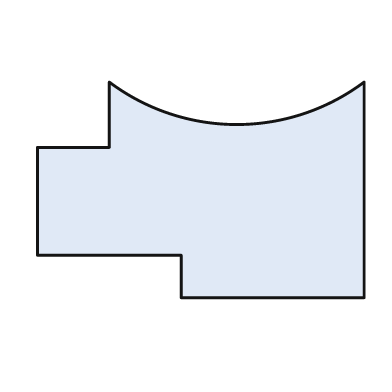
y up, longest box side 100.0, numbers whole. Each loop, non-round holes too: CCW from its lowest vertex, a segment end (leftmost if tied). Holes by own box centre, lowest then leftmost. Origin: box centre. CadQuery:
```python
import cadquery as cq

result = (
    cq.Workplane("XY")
    .moveTo(-6.0, -33.0)
    .lineTo(50.0, -33.0)
    .lineTo(50.0, 33.0)
    .threePointArc((11.0, 20.0), (-28.0, 33.0))
    .lineTo(-28.0, 13.0)
    .lineTo(-50.0, 13.0)
    .lineTo(-50.0, -20.0)
    .lineTo(-6.0, -20.0)
    .close()
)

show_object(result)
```